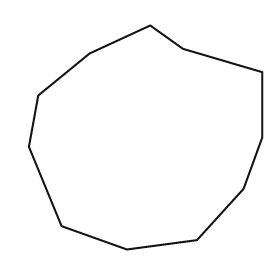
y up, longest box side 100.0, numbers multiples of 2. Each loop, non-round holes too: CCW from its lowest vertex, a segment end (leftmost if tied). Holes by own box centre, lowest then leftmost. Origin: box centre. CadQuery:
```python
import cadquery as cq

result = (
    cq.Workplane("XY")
    .moveTo(-8.0, -48.0)
    .lineTo(22.0, -44.0)
    .lineTo(42.0, -22.0)
    .lineTo(50.0, 0.0)
    .lineTo(50.0, 28.0)
    .lineTo(16.0, 38.0)
    .lineTo(2.0, 48.0)
    .lineTo(-24.0, 36.0)
    .lineTo(-46.0, 18.0)
    .lineTo(-50.0, -4.0)
    .lineTo(-36.0, -38.0)
    .close()
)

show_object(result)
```